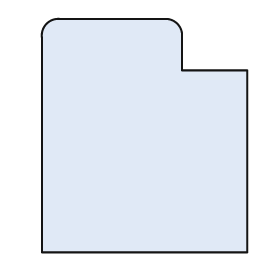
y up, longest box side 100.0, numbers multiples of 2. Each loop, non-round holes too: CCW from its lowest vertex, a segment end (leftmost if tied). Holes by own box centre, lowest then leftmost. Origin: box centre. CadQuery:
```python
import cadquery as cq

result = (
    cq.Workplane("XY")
    .moveTo(-44.0, -50.0)
    .lineTo(44.0, -50.0)
    .lineTo(44.0, 28.0)
    .lineTo(16.0, 28.0)
    .lineTo(16.0, 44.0)
    .threePointArc((14.0, 48.0), (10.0, 50.0))
    .lineTo(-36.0, 50.0)
    .threePointArc((-42.0, 48.0), (-44.0, 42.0))
    .close()
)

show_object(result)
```